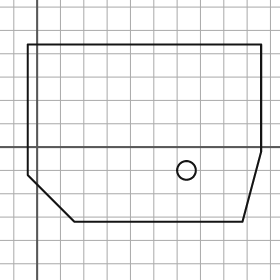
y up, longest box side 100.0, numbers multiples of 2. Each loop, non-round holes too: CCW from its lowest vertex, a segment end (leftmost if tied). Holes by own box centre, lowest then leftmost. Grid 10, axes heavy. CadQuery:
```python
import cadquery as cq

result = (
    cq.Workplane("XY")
    .moveTo(16.0, -32.0)
    .lineTo(88.0, -32.0)
    .lineTo(96.0, -2.0)
    .lineTo(96.0, 44.0)
    .lineTo(-4.0, 44.0)
    .lineTo(-4.0, -12.0)
    .close()
    .moveTo(64.0, -10.0)
    .circle(4.0)
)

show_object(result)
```